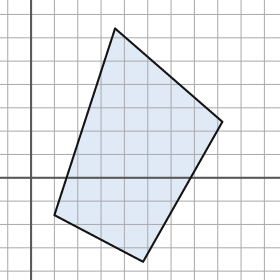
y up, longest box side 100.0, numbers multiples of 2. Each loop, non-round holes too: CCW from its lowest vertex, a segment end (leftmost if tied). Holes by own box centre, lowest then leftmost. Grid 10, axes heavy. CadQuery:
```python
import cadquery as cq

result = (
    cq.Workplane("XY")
    .moveTo(48.0, -36.0)
    .lineTo(82.0, 24.0)
    .lineTo(36.0, 64.0)
    .lineTo(10.0, -16.0)
    .close()
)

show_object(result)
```